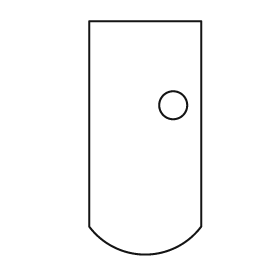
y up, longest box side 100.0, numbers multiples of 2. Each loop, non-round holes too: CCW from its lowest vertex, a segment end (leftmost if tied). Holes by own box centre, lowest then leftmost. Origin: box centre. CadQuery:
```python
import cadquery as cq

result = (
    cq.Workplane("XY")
    .moveTo(-24.0, -38.0)
    .threePointArc((0.0, -50.0), (24.0, -38.0))
    .lineTo(24.0, 50.0)
    .lineTo(-24.0, 50.0)
    .close()
    .moveTo(12.0, 14.0)
    .circle(6.0)
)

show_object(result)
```